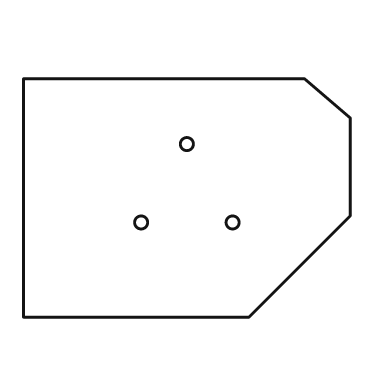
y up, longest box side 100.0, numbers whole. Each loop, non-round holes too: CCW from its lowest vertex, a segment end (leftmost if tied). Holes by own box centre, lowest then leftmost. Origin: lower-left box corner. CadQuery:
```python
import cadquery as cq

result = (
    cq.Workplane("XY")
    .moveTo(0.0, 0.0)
    .lineTo(69.0, 0.0)
    .lineTo(100.0, 31.0)
    .lineTo(100.0, 61.0)
    .lineTo(86.0, 73.0)
    .lineTo(0.0, 73.0)
    .close()
    .moveTo(36.0, 29.0)
    .circle(2.0)
    .moveTo(64.0, 29.0)
    .circle(2.0)
    .moveTo(50.0, 53.0)
    .circle(2.0)
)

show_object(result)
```